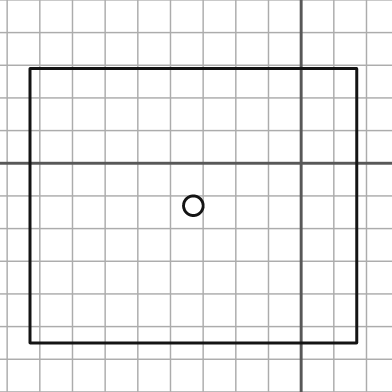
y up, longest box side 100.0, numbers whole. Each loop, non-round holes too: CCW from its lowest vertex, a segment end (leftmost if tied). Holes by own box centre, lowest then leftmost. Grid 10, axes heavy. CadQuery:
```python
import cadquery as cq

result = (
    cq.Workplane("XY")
    .moveTo(-83.0, -55.0)
    .lineTo(17.0, -55.0)
    .lineTo(17.0, 29.0)
    .lineTo(-83.0, 29.0)
    .close()
    .moveTo(-33.0, -13.0)
    .circle(3.0)
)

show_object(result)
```